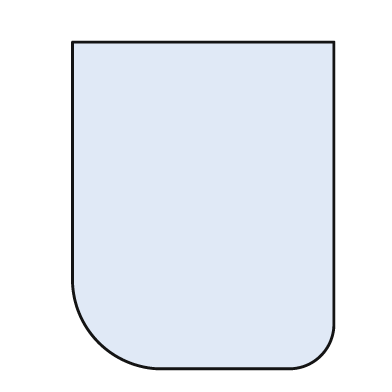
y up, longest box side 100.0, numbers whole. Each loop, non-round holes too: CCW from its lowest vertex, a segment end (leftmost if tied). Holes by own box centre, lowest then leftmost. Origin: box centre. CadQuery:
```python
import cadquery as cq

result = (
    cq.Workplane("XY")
    .moveTo(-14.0, -50.0)
    .lineTo(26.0, -50.0)
    .threePointArc((36.0, -46.0), (40.0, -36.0))
    .lineTo(40.0, 50.0)
    .lineTo(-40.0, 50.0)
    .lineTo(-40.0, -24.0)
    .threePointArc((-32.0, -42.0), (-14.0, -50.0))
    .close()
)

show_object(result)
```